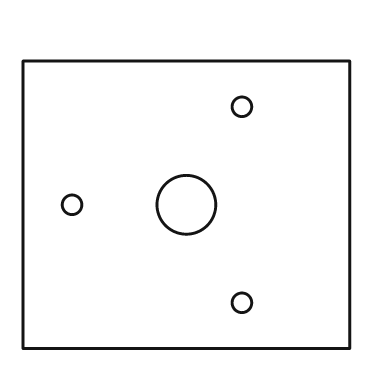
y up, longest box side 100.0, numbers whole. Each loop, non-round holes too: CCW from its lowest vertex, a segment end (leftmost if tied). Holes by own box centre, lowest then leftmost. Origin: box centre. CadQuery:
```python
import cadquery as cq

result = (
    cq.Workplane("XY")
    .moveTo(-50.0, -44.0)
    .lineTo(50.0, -44.0)
    .lineTo(50.0, 44.0)
    .lineTo(-50.0, 44.0)
    .close()
    .moveTo(17.0, -30.0)
    .circle(3.0)
    .moveTo(-35.0, 0.0)
    .circle(3.0)
    .moveTo(0.0, 0.0)
    .circle(9.0)
    .moveTo(17.0, 30.0)
    .circle(3.0)
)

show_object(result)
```